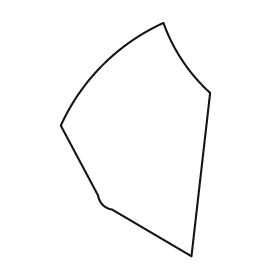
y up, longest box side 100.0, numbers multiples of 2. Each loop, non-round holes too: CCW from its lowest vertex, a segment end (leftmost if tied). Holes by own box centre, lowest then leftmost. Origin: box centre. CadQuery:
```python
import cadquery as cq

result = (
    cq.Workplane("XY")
    .moveTo(24.0, -50.0)
    .lineTo(32.0, 20.0)
    .threePointArc((20.0, 34.0), (12.0, 50.0))
    .threePointArc((-14.0, 32.0), (-32.0, 6.0))
    .lineTo(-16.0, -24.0)
    .threePointArc((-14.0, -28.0), (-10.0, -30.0))
    .close()
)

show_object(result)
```